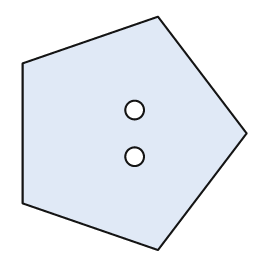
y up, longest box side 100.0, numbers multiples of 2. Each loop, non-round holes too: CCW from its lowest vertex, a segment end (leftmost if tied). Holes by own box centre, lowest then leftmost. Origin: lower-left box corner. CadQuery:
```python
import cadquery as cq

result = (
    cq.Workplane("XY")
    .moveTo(58.0, 0.0)
    .lineTo(96.0, 50.0)
    .lineTo(58.0, 100.0)
    .lineTo(0.0, 80.0)
    .lineTo(0.0, 20.0)
    .close()
    .moveTo(48.0, 40.0)
    .circle(4.0)
    .moveTo(48.0, 60.0)
    .circle(4.0)
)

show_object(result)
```